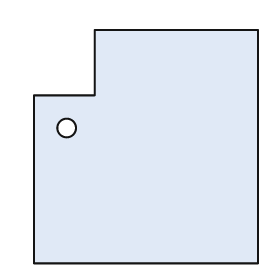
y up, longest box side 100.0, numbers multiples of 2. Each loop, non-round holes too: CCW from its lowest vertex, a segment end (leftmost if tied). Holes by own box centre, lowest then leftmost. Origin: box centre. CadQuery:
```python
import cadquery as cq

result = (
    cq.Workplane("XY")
    .moveTo(-48.0, -50.0)
    .lineTo(48.0, -50.0)
    .lineTo(48.0, 50.0)
    .lineTo(-22.0, 50.0)
    .lineTo(-22.0, 22.0)
    .lineTo(-48.0, 22.0)
    .close()
    .moveTo(-34.0, 8.0)
    .circle(4.0)
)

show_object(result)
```